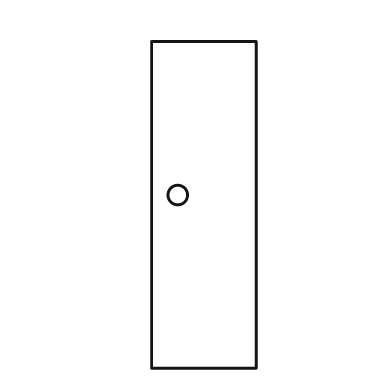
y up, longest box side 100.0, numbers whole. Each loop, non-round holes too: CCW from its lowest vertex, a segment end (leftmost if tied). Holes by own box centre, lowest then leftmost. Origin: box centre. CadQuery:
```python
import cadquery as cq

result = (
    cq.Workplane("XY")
    .moveTo(-16.0, -50.0)
    .lineTo(16.0, -50.0)
    .lineTo(16.0, 50.0)
    .lineTo(-16.0, 50.0)
    .close()
    .moveTo(-8.0, 3.0)
    .circle(3.0)
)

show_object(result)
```